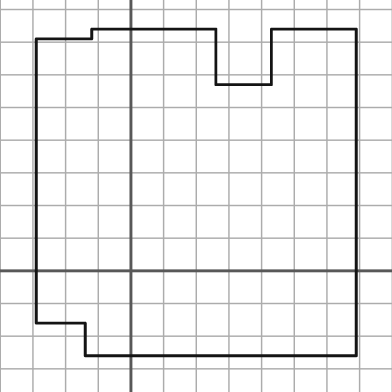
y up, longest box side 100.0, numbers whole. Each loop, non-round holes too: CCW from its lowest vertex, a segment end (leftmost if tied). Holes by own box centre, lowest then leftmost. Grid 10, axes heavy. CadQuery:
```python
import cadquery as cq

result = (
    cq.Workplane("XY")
    .moveTo(-14.0, -26.0)
    .lineTo(69.0, -26.0)
    .lineTo(69.0, 74.0)
    .lineTo(43.0, 74.0)
    .lineTo(43.0, 57.0)
    .lineTo(26.0, 57.0)
    .lineTo(26.0, 74.0)
    .lineTo(-12.0, 74.0)
    .lineTo(-12.0, 71.0)
    .lineTo(-29.0, 71.0)
    .lineTo(-29.0, -16.0)
    .lineTo(-14.0, -16.0)
    .close()
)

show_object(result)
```